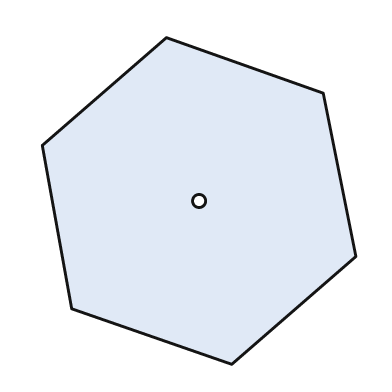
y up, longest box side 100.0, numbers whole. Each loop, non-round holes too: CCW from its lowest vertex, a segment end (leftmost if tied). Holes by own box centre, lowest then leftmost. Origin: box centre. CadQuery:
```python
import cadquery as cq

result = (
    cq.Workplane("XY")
    .moveTo(10.0, -50.0)
    .lineTo(48.0, -17.0)
    .lineTo(38.0, 33.0)
    .lineTo(-10.0, 50.0)
    .lineTo(-48.0, 17.0)
    .lineTo(-39.0, -33.0)
    .close()
    .moveTo(0.0, 0.0)
    .circle(2.0)
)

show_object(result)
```